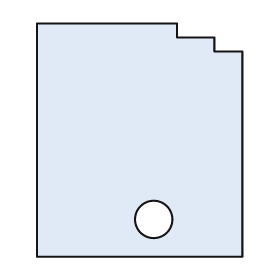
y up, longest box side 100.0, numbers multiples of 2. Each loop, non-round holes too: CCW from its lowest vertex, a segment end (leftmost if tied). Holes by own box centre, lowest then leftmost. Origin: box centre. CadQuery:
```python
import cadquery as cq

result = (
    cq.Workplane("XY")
    .moveTo(-44.0, -50.0)
    .lineTo(44.0, -50.0)
    .lineTo(44.0, 38.0)
    .lineTo(32.0, 38.0)
    .lineTo(32.0, 44.0)
    .lineTo(16.0, 44.0)
    .lineTo(16.0, 50.0)
    .lineTo(-44.0, 50.0)
    .close()
    .moveTo(6.0, -34.0)
    .circle(8.0)
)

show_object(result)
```